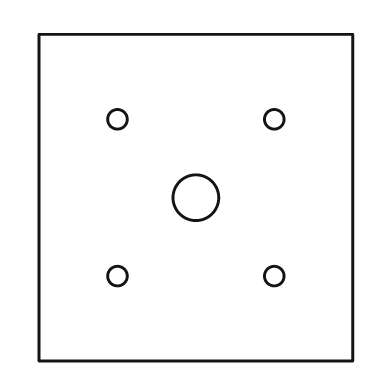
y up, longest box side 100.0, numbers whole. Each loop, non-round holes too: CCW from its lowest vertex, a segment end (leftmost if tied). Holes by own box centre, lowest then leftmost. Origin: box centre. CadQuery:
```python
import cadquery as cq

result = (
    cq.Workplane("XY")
    .moveTo(-48.0, -50.0)
    .lineTo(48.0, -50.0)
    .lineTo(48.0, 50.0)
    .lineTo(-48.0, 50.0)
    .close()
    .moveTo(-24.0, -24.0)
    .circle(3.0)
    .moveTo(24.0, -24.0)
    .circle(3.0)
    .moveTo(0.0, 0.0)
    .circle(7.0)
    .moveTo(-24.0, 24.0)
    .circle(3.0)
    .moveTo(24.0, 24.0)
    .circle(3.0)
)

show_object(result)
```